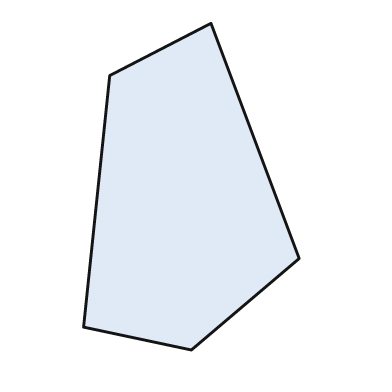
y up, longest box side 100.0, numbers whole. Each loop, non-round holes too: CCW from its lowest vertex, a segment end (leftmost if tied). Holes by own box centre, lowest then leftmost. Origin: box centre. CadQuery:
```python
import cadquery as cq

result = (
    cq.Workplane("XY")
    .moveTo(0.0, -50.0)
    .lineTo(33.0, -22.0)
    .lineTo(6.0, 50.0)
    .lineTo(-25.0, 34.0)
    .lineTo(-33.0, -43.0)
    .close()
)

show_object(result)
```